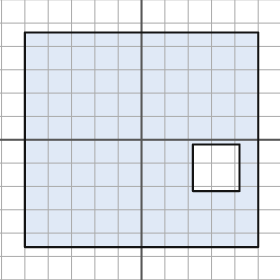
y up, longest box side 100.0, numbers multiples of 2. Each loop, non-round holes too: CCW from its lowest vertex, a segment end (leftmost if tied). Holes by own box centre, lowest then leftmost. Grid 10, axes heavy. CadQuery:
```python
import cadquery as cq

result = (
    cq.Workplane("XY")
    .moveTo(-50.0, -46.0)
    .lineTo(50.0, -46.0)
    .lineTo(50.0, 46.0)
    .lineTo(-50.0, 46.0)
    .close()
    .moveTo(22.0, -22.0)
    .lineTo(42.0, -22.0)
    .lineTo(42.0, -2.0)
    .lineTo(22.0, -2.0)
    .close()
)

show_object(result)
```